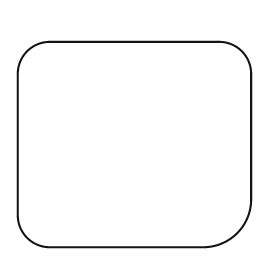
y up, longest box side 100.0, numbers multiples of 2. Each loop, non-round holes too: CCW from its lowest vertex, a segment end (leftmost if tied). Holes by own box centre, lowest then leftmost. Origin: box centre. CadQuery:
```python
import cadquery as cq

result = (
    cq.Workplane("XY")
    .moveTo(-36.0, -44.0)
    .lineTo(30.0, -44.0)
    .threePointArc((44.0, -38.0), (50.0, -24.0))
    .lineTo(50.0, 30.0)
    .threePointArc((46.0, 40.0), (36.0, 44.0))
    .lineTo(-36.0, 44.0)
    .threePointArc((-46.0, 40.0), (-50.0, 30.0))
    .lineTo(-50.0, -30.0)
    .threePointArc((-46.0, -40.0), (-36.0, -44.0))
    .close()
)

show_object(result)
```